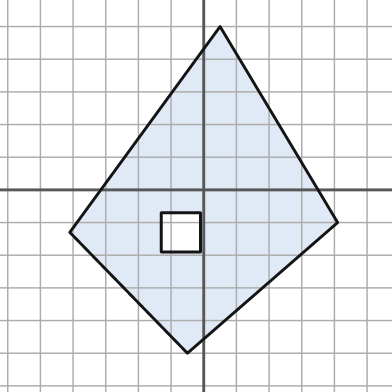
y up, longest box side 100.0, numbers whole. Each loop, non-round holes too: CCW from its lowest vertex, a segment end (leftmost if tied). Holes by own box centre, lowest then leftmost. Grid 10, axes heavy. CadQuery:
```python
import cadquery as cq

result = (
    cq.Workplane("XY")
    .moveTo(-5.0, -50.0)
    .lineTo(41.0, -10.0)
    .lineTo(5.0, 50.0)
    .lineTo(-41.0, -13.0)
    .close()
    .moveTo(-13.0, -19.0)
    .lineTo(-1.0, -19.0)
    .lineTo(-1.0, -7.0)
    .lineTo(-13.0, -7.0)
    .close()
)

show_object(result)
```